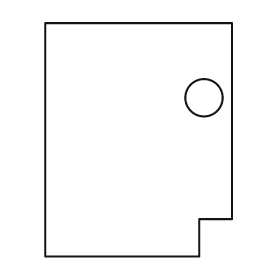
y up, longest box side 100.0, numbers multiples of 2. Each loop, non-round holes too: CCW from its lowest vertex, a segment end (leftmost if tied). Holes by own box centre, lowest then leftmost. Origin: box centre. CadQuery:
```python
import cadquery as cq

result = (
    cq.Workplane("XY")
    .moveTo(-40.0, -50.0)
    .lineTo(26.0, -50.0)
    .lineTo(26.0, -34.0)
    .lineTo(40.0, -34.0)
    .lineTo(40.0, 50.0)
    .lineTo(-40.0, 50.0)
    .close()
    .moveTo(28.0, 18.0)
    .circle(8.0)
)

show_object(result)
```